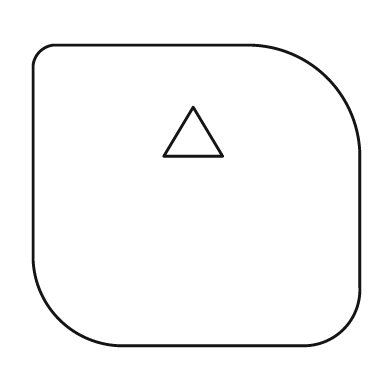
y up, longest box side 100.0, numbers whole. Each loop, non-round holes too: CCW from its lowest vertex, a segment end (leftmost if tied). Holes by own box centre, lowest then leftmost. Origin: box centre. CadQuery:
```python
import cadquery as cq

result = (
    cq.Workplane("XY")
    .moveTo(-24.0, -46.0)
    .lineTo(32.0, -46.0)
    .threePointArc((45.0, -41.0), (50.0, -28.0))
    .lineTo(50.0, 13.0)
    .threePointArc((40.0, 36.0), (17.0, 46.0))
    .lineTo(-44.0, 46.0)
    .threePointArc((-48.0, 44.0), (-50.0, 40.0))
    .lineTo(-50.0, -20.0)
    .threePointArc((-42.0, -38.0), (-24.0, -46.0))
    .close()
    .moveTo(-10.0, 12.0)
    .lineTo(8.0, 12.0)
    .lineTo(-1.0, 27.0)
    .close()
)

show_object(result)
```